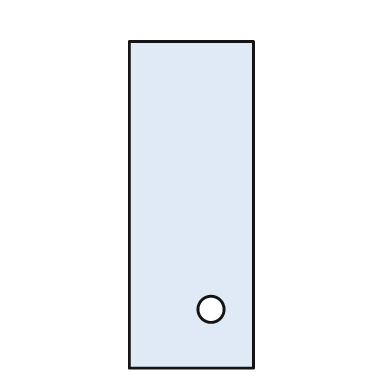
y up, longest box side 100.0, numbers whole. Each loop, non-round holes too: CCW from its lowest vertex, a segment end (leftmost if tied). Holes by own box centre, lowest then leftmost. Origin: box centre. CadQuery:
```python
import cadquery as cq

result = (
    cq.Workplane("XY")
    .moveTo(-19.0, -50.0)
    .lineTo(19.0, -50.0)
    .lineTo(19.0, 50.0)
    .lineTo(-19.0, 50.0)
    .close()
    .moveTo(6.0, -32.0)
    .circle(4.0)
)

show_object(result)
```